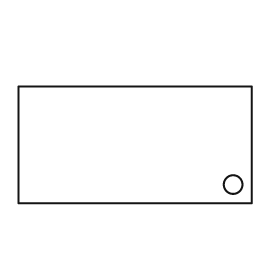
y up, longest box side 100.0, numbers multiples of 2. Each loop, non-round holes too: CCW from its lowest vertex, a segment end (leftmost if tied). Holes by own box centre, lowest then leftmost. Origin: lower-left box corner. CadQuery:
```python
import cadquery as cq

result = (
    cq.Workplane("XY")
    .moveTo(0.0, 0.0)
    .lineTo(100.0, 0.0)
    .lineTo(100.0, 50.0)
    .lineTo(0.0, 50.0)
    .close()
    .moveTo(92.0, 8.0)
    .circle(4.0)
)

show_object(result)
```